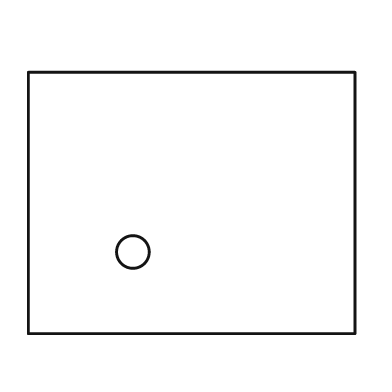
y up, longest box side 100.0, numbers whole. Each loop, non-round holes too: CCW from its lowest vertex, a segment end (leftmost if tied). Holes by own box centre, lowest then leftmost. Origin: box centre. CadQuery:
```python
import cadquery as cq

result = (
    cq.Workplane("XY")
    .moveTo(-50.0, -40.0)
    .lineTo(50.0, -40.0)
    .lineTo(50.0, 40.0)
    .lineTo(-50.0, 40.0)
    .close()
    .moveTo(-18.0, -15.0)
    .circle(5.0)
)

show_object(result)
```